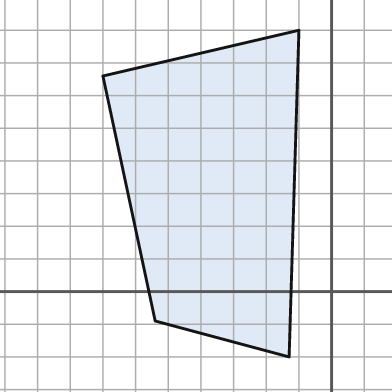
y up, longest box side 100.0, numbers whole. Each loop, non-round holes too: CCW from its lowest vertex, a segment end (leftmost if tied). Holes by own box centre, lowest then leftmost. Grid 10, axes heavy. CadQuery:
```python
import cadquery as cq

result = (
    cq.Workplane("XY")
    .moveTo(-13.0, -20.0)
    .lineTo(-10.0, 80.0)
    .lineTo(-70.0, 66.0)
    .lineTo(-54.0, -9.0)
    .close()
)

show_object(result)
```